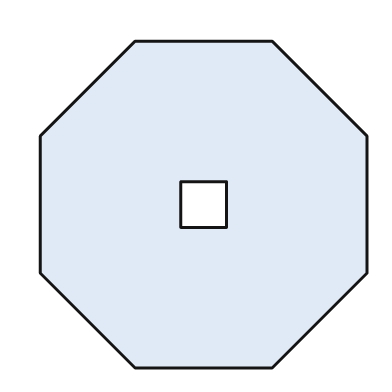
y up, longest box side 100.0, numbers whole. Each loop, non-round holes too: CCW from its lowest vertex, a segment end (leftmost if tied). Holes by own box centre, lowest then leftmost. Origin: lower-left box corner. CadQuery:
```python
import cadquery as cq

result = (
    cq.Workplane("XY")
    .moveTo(29.0, 0.0)
    .lineTo(71.0, 0.0)
    .lineTo(100.0, 29.0)
    .lineTo(100.0, 71.0)
    .lineTo(71.0, 100.0)
    .lineTo(29.0, 100.0)
    .lineTo(0.0, 71.0)
    .lineTo(0.0, 29.0)
    .close()
    .moveTo(43.0, 43.0)
    .lineTo(57.0, 43.0)
    .lineTo(57.0, 57.0)
    .lineTo(43.0, 57.0)
    .close()
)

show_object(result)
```